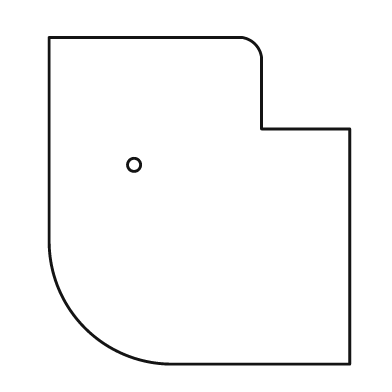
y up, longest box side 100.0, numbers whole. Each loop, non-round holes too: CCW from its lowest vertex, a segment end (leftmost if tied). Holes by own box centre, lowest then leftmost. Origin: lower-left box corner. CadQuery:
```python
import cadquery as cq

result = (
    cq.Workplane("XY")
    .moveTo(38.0, 0.0)
    .lineTo(92.0, 0.0)
    .lineTo(92.0, 72.0)
    .lineTo(65.0, 72.0)
    .lineTo(65.0, 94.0)
    .threePointArc((63.0, 98.0), (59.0, 100.0))
    .lineTo(0.0, 100.0)
    .lineTo(0.0, 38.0)
    .threePointArc((11.0, 11.0), (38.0, 0.0))
    .close()
    .moveTo(26.0, 61.0)
    .circle(2.0)
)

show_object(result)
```